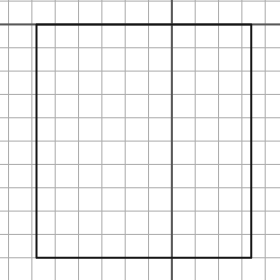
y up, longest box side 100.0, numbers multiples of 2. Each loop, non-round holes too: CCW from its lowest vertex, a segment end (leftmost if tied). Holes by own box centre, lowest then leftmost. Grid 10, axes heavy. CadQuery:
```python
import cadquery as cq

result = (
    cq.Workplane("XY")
    .moveTo(-58.0, -100.0)
    .lineTo(34.0, -100.0)
    .lineTo(34.0, 0.0)
    .lineTo(-58.0, 0.0)
    .close()
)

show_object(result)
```